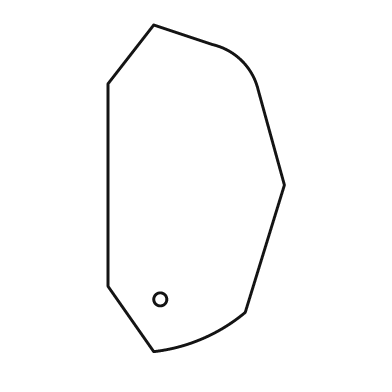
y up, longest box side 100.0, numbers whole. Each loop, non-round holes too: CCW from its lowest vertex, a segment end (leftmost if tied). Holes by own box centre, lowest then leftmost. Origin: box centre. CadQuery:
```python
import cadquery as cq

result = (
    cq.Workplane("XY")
    .moveTo(-13.0, -50.0)
    .threePointArc((2.0, -46.0), (15.0, -38.0))
    .lineTo(27.0, 1.0)
    .lineTo(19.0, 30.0)
    .threePointArc((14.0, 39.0), (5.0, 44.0))
    .lineTo(-13.0, 50.0)
    .lineTo(-27.0, 32.0)
    .lineTo(-27.0, -30.0)
    .close()
    .moveTo(-11.0, -34.0)
    .circle(2.0)
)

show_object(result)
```